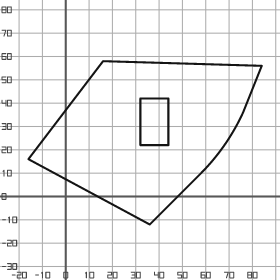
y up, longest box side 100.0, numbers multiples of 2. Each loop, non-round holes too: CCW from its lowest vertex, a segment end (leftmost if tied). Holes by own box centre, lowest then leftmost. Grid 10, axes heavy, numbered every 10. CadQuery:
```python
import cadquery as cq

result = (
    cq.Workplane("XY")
    .moveTo(36.0, -12.0)
    .lineTo(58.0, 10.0)
    .threePointArc((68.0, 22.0), (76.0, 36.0))
    .lineTo(84.0, 56.0)
    .lineTo(16.0, 58.0)
    .lineTo(-16.0, 16.0)
    .close()
    .moveTo(32.0, 22.0)
    .lineTo(44.0, 22.0)
    .lineTo(44.0, 42.0)
    .lineTo(32.0, 42.0)
    .close()
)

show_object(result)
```